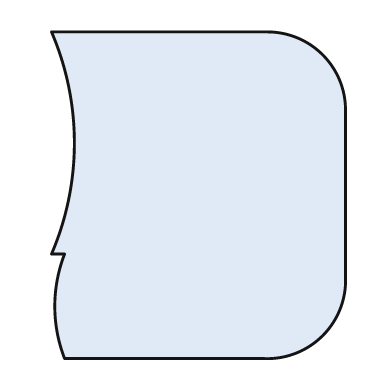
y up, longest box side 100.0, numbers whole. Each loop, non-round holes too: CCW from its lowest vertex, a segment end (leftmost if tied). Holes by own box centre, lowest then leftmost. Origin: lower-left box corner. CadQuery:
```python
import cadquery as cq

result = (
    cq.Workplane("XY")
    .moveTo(4.0, 0.0)
    .lineTo(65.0, 0.0)
    .threePointArc((83.0, 7.0), (90.0, 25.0))
    .lineTo(90.0, 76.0)
    .threePointArc((83.0, 93.0), (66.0, 100.0))
    .lineTo(0.0, 100.0)
    .threePointArc((7.0, 66.0), (0.0, 32.0))
    .lineTo(4.0, 32.0)
    .threePointArc((1.0, 16.0), (4.0, 0.0))
    .close()
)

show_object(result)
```